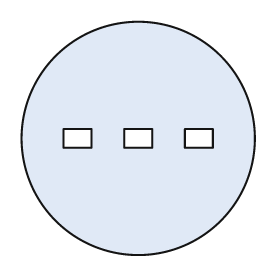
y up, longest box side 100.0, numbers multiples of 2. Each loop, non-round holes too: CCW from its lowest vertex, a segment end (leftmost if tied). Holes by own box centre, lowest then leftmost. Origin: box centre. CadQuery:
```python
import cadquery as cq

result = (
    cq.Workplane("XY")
    .moveTo(0.0, 0.0)
    .circle(50.0)
    .moveTo(-32.0, -4.0)
    .lineTo(-20.0, -4.0)
    .lineTo(-20.0, 4.0)
    .lineTo(-32.0, 4.0)
    .close()
    .moveTo(-6.0, -4.0)
    .lineTo(6.0, -4.0)
    .lineTo(6.0, 4.0)
    .lineTo(-6.0, 4.0)
    .close()
    .moveTo(20.0, -4.0)
    .lineTo(32.0, -4.0)
    .lineTo(32.0, 4.0)
    .lineTo(20.0, 4.0)
    .close()
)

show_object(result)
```